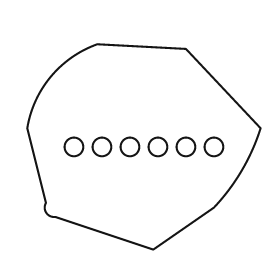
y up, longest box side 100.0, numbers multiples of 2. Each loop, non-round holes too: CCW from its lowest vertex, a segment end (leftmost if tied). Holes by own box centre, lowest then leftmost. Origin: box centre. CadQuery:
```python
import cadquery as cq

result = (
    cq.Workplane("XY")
    .moveTo(4.0, -44.0)
    .lineTo(30.0, -26.0)
    .threePointArc((42.0, -10.0), (50.0, 8.0))
    .lineTo(18.0, 42.0)
    .lineTo(-20.0, 44.0)
    .threePointArc((-40.0, 30.0), (-50.0, 8.0))
    .lineTo(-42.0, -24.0)
    .threePointArc((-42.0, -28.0), (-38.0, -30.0))
    .close()
    .moveTo(-30.0, 0.0)
    .circle(4.0)
    .moveTo(-18.0, 0.0)
    .circle(4.0)
    .moveTo(-6.0, 0.0)
    .circle(4.0)
    .moveTo(6.0, 0.0)
    .circle(4.0)
    .moveTo(18.0, 0.0)
    .circle(4.0)
    .moveTo(30.0, 0.0)
    .circle(4.0)
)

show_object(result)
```